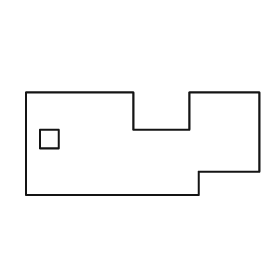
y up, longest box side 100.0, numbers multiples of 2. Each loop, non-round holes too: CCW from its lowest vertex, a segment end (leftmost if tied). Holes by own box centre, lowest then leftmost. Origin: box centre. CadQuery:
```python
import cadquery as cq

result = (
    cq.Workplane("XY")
    .moveTo(-50.0, -22.0)
    .lineTo(24.0, -22.0)
    .lineTo(24.0, -12.0)
    .lineTo(50.0, -12.0)
    .lineTo(50.0, 22.0)
    .lineTo(20.0, 22.0)
    .lineTo(20.0, 6.0)
    .lineTo(-4.0, 6.0)
    .lineTo(-4.0, 22.0)
    .lineTo(-50.0, 22.0)
    .close()
    .moveTo(-44.0, -2.0)
    .lineTo(-36.0, -2.0)
    .lineTo(-36.0, 6.0)
    .lineTo(-44.0, 6.0)
    .close()
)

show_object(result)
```